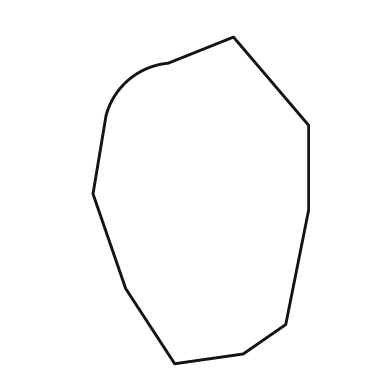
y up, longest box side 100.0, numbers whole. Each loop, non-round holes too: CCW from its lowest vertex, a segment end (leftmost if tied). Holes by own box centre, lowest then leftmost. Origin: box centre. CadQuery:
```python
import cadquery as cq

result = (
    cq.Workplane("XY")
    .moveTo(-8.0, -50.0)
    .lineTo(13.0, -47.0)
    .lineTo(26.0, -38.0)
    .lineTo(33.0, -3.0)
    .lineTo(33.0, 23.0)
    .lineTo(10.0, 50.0)
    .lineTo(-10.0, 42.0)
    .threePointArc((-22.0, 37.0), (-29.0, 26.0))
    .lineTo(-33.0, 2.0)
    .lineTo(-23.0, -27.0)
    .close()
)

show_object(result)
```